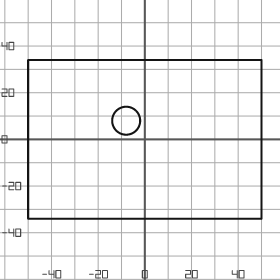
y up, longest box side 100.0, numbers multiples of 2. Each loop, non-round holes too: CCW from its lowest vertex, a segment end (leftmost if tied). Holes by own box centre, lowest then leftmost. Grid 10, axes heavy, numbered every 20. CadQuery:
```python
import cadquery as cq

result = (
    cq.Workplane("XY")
    .moveTo(-50.0, -34.0)
    .lineTo(50.0, -34.0)
    .lineTo(50.0, 34.0)
    .lineTo(-50.0, 34.0)
    .close()
    .moveTo(-8.0, 8.0)
    .circle(6.0)
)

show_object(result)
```